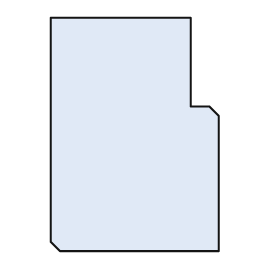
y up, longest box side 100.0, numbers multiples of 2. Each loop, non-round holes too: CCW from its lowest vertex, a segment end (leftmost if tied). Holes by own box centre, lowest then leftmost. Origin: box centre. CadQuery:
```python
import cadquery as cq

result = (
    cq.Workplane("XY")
    .moveTo(-32.0, -50.0)
    .lineTo(36.0, -50.0)
    .lineTo(36.0, 8.0)
    .lineTo(32.0, 12.0)
    .lineTo(24.0, 12.0)
    .lineTo(24.0, 50.0)
    .lineTo(-36.0, 50.0)
    .lineTo(-36.0, -46.0)
    .close()
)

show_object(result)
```